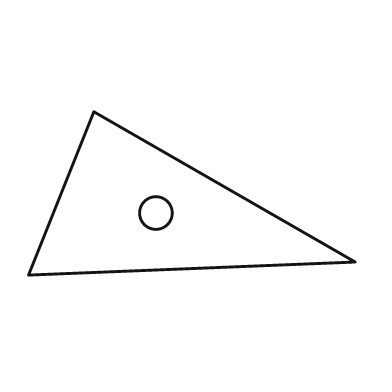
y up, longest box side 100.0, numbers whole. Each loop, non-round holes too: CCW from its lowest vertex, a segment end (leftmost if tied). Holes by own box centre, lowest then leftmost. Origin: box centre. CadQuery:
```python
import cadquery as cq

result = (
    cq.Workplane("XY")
    .moveTo(-50.0, -25.0)
    .lineTo(50.0, -21.0)
    .lineTo(-30.0, 25.0)
    .close()
    .moveTo(-11.0, -6.0)
    .circle(5.0)
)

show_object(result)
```